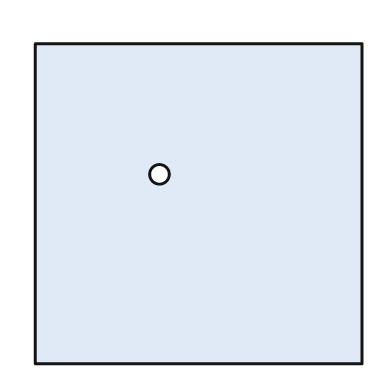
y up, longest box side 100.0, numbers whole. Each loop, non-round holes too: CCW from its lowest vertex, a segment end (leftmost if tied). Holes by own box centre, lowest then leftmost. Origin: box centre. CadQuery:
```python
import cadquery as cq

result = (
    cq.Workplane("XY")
    .moveTo(-50.0, -49.0)
    .lineTo(50.0, -49.0)
    .lineTo(50.0, 49.0)
    .lineTo(-50.0, 49.0)
    .close()
    .moveTo(-12.0, 9.0)
    .circle(3.0)
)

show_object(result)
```